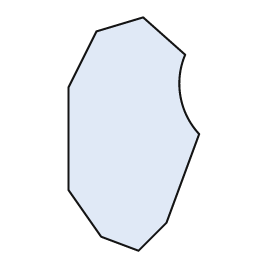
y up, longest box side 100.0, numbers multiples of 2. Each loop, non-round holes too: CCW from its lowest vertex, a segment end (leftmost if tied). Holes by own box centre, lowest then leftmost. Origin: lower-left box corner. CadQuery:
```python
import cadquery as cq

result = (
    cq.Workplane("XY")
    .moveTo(30.0, 0.0)
    .lineTo(42.0, 12.0)
    .lineTo(56.0, 50.0)
    .threePointArc((48.0, 66.0), (50.0, 84.0))
    .lineTo(32.0, 100.0)
    .lineTo(12.0, 94.0)
    .lineTo(0.0, 70.0)
    .lineTo(0.0, 26.0)
    .lineTo(14.0, 6.0)
    .close()
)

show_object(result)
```